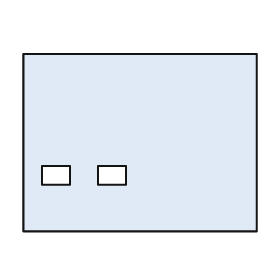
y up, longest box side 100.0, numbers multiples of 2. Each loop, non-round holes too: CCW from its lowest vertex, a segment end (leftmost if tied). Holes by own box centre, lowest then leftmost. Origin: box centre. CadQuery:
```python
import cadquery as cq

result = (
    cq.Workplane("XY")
    .moveTo(-50.0, -38.0)
    .lineTo(50.0, -38.0)
    .lineTo(50.0, 38.0)
    .lineTo(-50.0, 38.0)
    .close()
    .moveTo(-42.0, -18.0)
    .lineTo(-30.0, -18.0)
    .lineTo(-30.0, -10.0)
    .lineTo(-42.0, -10.0)
    .close()
    .moveTo(-18.0, -18.0)
    .lineTo(-6.0, -18.0)
    .lineTo(-6.0, -10.0)
    .lineTo(-18.0, -10.0)
    .close()
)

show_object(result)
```